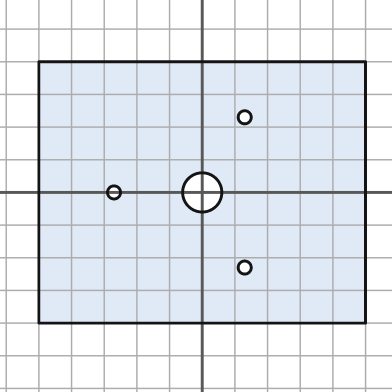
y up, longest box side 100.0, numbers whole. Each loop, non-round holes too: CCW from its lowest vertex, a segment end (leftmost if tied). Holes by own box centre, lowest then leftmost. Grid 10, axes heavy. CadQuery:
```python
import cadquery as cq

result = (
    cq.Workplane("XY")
    .moveTo(-50.0, -40.0)
    .lineTo(50.0, -40.0)
    .lineTo(50.0, 40.0)
    .lineTo(-50.0, 40.0)
    .close()
    .moveTo(13.0, -23.0)
    .circle(2.0)
    .moveTo(-27.0, 0.0)
    .circle(2.0)
    .moveTo(0.0, 0.0)
    .circle(6.0)
    .moveTo(13.0, 23.0)
    .circle(2.0)
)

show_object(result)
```